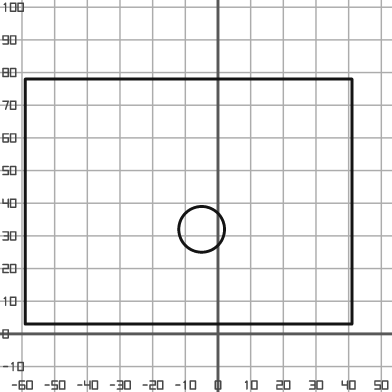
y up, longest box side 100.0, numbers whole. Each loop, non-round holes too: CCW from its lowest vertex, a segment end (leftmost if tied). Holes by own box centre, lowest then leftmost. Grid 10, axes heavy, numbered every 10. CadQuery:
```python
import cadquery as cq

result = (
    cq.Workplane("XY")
    .moveTo(-59.0, 3.0)
    .lineTo(41.0, 3.0)
    .lineTo(41.0, 78.0)
    .lineTo(-59.0, 78.0)
    .close()
    .moveTo(-5.0, 32.0)
    .circle(7.0)
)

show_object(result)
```